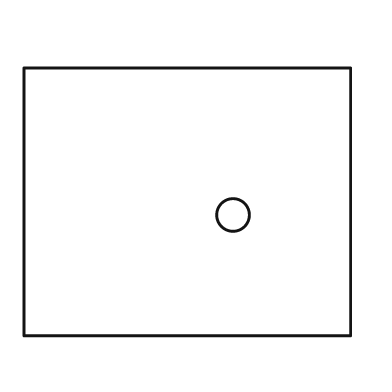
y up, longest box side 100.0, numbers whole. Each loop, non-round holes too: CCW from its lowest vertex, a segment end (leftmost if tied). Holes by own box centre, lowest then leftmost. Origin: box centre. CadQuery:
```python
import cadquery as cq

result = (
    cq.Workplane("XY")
    .moveTo(-50.0, -41.0)
    .lineTo(50.0, -41.0)
    .lineTo(50.0, 41.0)
    .lineTo(-50.0, 41.0)
    .close()
    .moveTo(14.0, -4.0)
    .circle(5.0)
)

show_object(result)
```